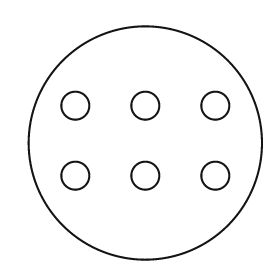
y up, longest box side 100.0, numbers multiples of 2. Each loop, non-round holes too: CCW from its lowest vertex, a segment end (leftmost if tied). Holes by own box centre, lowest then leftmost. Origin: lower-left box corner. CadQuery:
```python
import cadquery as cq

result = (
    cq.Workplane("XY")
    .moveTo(50.0, 50.0)
    .circle(50.0)
    .moveTo(20.0, 36.0)
    .circle(6.0)
    .moveTo(50.0, 36.0)
    .circle(6.0)
    .moveTo(80.0, 36.0)
    .circle(6.0)
    .moveTo(20.0, 66.0)
    .circle(6.0)
    .moveTo(50.0, 66.0)
    .circle(6.0)
    .moveTo(80.0, 66.0)
    .circle(6.0)
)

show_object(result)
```